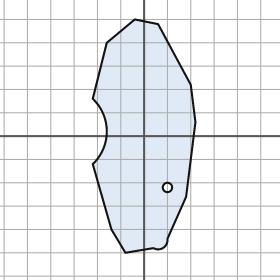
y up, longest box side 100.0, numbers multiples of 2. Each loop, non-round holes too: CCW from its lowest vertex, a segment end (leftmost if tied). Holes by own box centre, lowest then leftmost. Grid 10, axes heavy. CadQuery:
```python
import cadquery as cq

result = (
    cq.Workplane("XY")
    .moveTo(-8.0, -50.0)
    .lineTo(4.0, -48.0)
    .threePointArc((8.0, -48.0), (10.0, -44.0))
    .lineTo(18.0, -26.0)
    .lineTo(22.0, 6.0)
    .lineTo(20.0, 22.0)
    .lineTo(6.0, 48.0)
    .lineTo(-4.0, 50.0)
    .lineTo(-16.0, 40.0)
    .lineTo(-22.0, 16.0)
    .threePointArc((-16.0, 2.0), (-22.0, -12.0))
    .lineTo(-14.0, -40.0)
    .close()
    .moveTo(10.0, -22.0)
    .circle(2.0)
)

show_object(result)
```